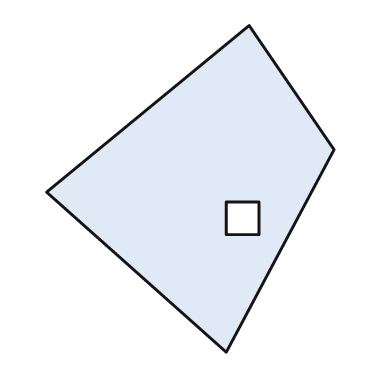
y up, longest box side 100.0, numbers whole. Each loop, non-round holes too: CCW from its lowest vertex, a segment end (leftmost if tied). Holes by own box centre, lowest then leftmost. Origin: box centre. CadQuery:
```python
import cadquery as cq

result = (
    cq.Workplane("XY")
    .moveTo(11.0, -50.0)
    .lineTo(44.0, 12.0)
    .lineTo(18.0, 50.0)
    .lineTo(-44.0, -1.0)
    .close()
    .moveTo(11.0, -14.0)
    .lineTo(21.0, -14.0)
    .lineTo(21.0, -4.0)
    .lineTo(11.0, -4.0)
    .close()
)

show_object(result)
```